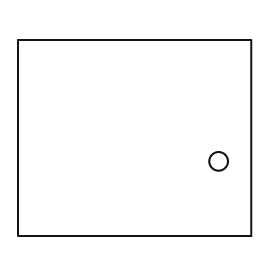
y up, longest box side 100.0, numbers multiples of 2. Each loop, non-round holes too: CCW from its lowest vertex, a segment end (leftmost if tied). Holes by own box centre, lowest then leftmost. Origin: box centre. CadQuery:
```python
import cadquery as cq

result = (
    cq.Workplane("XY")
    .moveTo(-50.0, -42.0)
    .lineTo(50.0, -42.0)
    .lineTo(50.0, 42.0)
    .lineTo(-50.0, 42.0)
    .close()
    .moveTo(36.0, -10.0)
    .circle(4.0)
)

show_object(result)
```